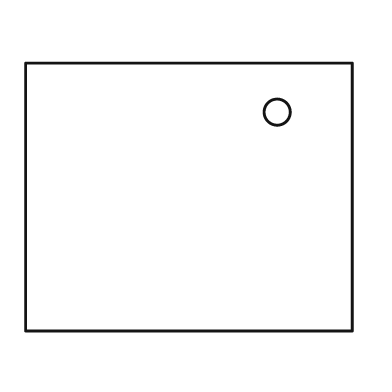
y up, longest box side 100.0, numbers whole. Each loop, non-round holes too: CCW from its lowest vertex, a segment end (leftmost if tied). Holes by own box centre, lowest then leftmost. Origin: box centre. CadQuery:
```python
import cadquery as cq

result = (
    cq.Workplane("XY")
    .moveTo(-50.0, -41.0)
    .lineTo(50.0, -41.0)
    .lineTo(50.0, 41.0)
    .lineTo(-50.0, 41.0)
    .close()
    .moveTo(27.0, 26.0)
    .circle(4.0)
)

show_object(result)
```